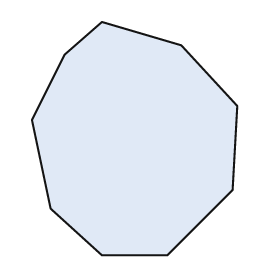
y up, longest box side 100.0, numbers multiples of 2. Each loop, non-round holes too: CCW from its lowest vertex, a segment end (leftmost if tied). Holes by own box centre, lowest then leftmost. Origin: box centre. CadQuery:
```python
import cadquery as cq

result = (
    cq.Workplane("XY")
    .moveTo(-14.0, -50.0)
    .lineTo(14.0, -50.0)
    .lineTo(42.0, -22.0)
    .lineTo(44.0, 14.0)
    .lineTo(20.0, 40.0)
    .lineTo(-14.0, 50.0)
    .lineTo(-30.0, 36.0)
    .lineTo(-44.0, 8.0)
    .lineTo(-36.0, -30.0)
    .close()
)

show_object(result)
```